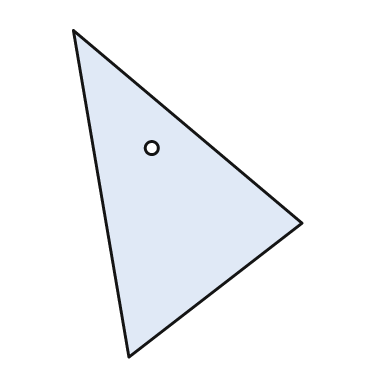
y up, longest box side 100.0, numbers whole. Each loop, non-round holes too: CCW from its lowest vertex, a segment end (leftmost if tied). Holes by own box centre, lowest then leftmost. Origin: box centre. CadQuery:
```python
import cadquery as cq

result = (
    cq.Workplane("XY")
    .moveTo(-18.0, -50.0)
    .lineTo(35.0, -9.0)
    .lineTo(-35.0, 50.0)
    .close()
    .moveTo(-11.0, 14.0)
    .circle(2.0)
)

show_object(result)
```